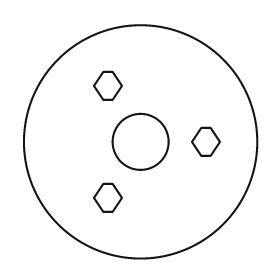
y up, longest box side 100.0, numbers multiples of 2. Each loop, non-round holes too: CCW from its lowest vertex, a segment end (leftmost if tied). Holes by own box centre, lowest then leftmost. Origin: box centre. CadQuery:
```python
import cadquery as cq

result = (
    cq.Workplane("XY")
    .moveTo(0.0, 0.0)
    .circle(50.0)
    .moveTo(-16.0, -30.0)
    .lineTo(-12.0, -30.0)
    .lineTo(-8.0, -24.0)
    .lineTo(-12.0, -18.0)
    .lineTo(-16.0, -18.0)
    .lineTo(-20.0, -24.0)
    .close()
    .moveTo(0.0, 0.0)
    .circle(12.0)
    .moveTo(26.0, -6.0)
    .lineTo(30.0, -6.0)
    .lineTo(34.0, 0.0)
    .lineTo(30.0, 6.0)
    .lineTo(26.0, 6.0)
    .lineTo(22.0, 0.0)
    .close()
    .moveTo(-16.0, 18.0)
    .lineTo(-12.0, 18.0)
    .lineTo(-8.0, 24.0)
    .lineTo(-12.0, 30.0)
    .lineTo(-16.0, 30.0)
    .lineTo(-20.0, 24.0)
    .close()
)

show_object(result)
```